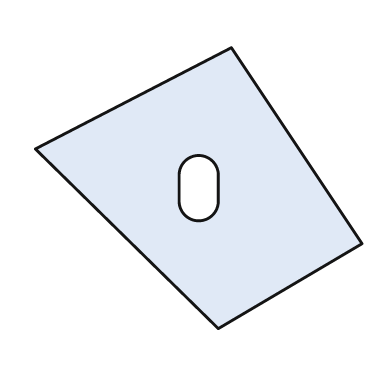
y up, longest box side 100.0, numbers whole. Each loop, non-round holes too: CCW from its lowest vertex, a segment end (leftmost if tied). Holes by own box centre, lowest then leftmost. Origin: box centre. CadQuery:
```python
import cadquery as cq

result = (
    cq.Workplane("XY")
    .moveTo(6.0, -43.0)
    .lineTo(50.0, -17.0)
    .lineTo(10.0, 43.0)
    .lineTo(-50.0, 12.0)
    .close()
    .moveTo(-6.0, -4.0)
    .threePointArc((0.0, -10.0), (6.0, -4.0))
    .lineTo(6.0, 4.0)
    .threePointArc((0.0, 10.0), (-6.0, 4.0))
    .close()
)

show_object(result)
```